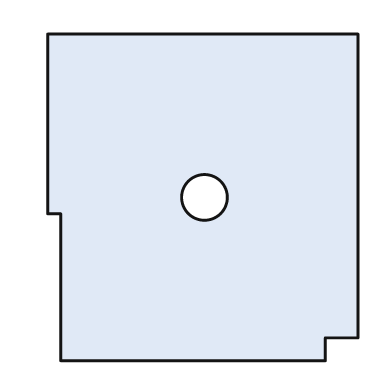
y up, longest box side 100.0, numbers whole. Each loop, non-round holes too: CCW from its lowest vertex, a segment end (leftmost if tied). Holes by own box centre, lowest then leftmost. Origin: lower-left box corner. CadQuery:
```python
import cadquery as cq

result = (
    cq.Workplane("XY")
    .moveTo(4.0, 0.0)
    .lineTo(85.0, 0.0)
    .lineTo(85.0, 7.0)
    .lineTo(95.0, 7.0)
    .lineTo(95.0, 100.0)
    .lineTo(0.0, 100.0)
    .lineTo(0.0, 45.0)
    .lineTo(4.0, 45.0)
    .close()
    .moveTo(48.0, 50.0)
    .circle(7.0)
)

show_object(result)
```